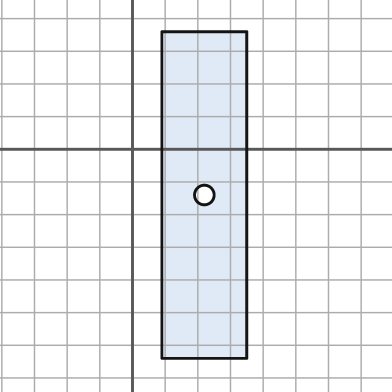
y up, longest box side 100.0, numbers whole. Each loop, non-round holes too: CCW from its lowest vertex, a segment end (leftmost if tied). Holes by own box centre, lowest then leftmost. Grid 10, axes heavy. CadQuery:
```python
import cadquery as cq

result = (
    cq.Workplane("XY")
    .moveTo(9.0, -64.0)
    .lineTo(35.0, -64.0)
    .lineTo(35.0, 36.0)
    .lineTo(9.0, 36.0)
    .close()
    .moveTo(22.0, -14.0)
    .circle(3.0)
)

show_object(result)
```